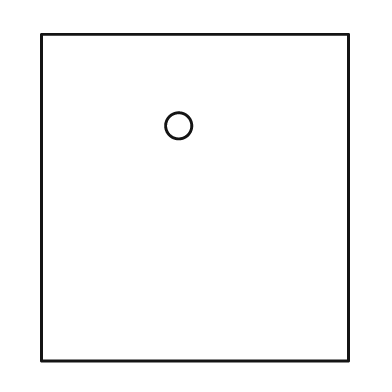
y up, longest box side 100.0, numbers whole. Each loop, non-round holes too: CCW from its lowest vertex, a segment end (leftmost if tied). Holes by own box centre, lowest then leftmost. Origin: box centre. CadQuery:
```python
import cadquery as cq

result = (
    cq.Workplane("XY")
    .moveTo(-47.0, -50.0)
    .lineTo(47.0, -50.0)
    .lineTo(47.0, 50.0)
    .lineTo(-47.0, 50.0)
    .close()
    .moveTo(-5.0, 22.0)
    .circle(4.0)
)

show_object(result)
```